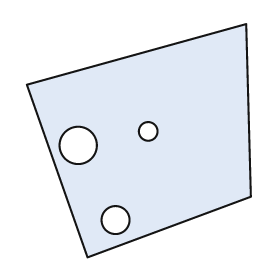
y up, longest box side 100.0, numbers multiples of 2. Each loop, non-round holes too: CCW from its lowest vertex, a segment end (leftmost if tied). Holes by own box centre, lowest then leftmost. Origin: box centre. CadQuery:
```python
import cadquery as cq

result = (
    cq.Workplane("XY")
    .moveTo(-22.0, -50.0)
    .lineTo(48.0, -24.0)
    .lineTo(46.0, 50.0)
    .lineTo(-48.0, 24.0)
    .close()
    .moveTo(-10.0, -34.0)
    .circle(6.0)
    .moveTo(-26.0, -2.0)
    .circle(8.0)
    .moveTo(4.0, 4.0)
    .circle(4.0)
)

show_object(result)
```